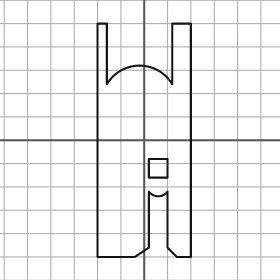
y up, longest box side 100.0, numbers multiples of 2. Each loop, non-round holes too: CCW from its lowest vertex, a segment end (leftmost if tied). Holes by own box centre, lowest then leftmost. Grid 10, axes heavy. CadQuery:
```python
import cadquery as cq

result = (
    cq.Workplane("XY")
    .moveTo(-20.0, -50.0)
    .lineTo(-4.0, -50.0)
    .lineTo(2.0, -46.0)
    .lineTo(2.0, -22.0)
    .threePointArc((6.0, -24.0), (10.0, -22.0))
    .lineTo(10.0, -46.0)
    .lineTo(14.0, -50.0)
    .lineTo(20.0, -50.0)
    .lineTo(20.0, 50.0)
    .lineTo(12.0, 50.0)
    .lineTo(12.0, 24.0)
    .threePointArc((-2.0, 32.0), (-16.0, 24.0))
    .lineTo(-16.0, 50.0)
    .lineTo(-20.0, 50.0)
    .close()
    .moveTo(2.0, -16.0)
    .lineTo(10.0, -16.0)
    .lineTo(10.0, -8.0)
    .lineTo(2.0, -8.0)
    .close()
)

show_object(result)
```